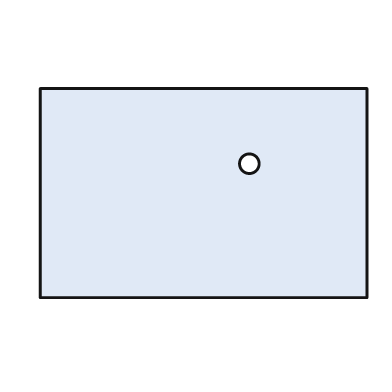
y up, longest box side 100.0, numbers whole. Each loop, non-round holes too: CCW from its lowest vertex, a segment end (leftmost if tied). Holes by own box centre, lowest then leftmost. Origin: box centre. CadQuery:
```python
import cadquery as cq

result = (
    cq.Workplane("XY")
    .moveTo(-50.0, -32.0)
    .lineTo(50.0, -32.0)
    .lineTo(50.0, 32.0)
    .lineTo(-50.0, 32.0)
    .close()
    .moveTo(14.0, 9.0)
    .circle(3.0)
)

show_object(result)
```